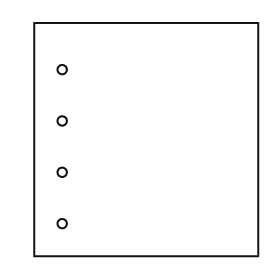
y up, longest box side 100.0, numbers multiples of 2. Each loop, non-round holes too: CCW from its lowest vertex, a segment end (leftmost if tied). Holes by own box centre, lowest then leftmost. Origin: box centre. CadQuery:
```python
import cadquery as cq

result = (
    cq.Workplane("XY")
    .moveTo(-48.0, -50.0)
    .lineTo(48.0, -50.0)
    .lineTo(48.0, 50.0)
    .lineTo(-48.0, 50.0)
    .close()
    .moveTo(-36.0, -36.0)
    .circle(2.0)
    .moveTo(-36.0, -14.0)
    .circle(2.0)
    .moveTo(-36.0, 8.0)
    .circle(2.0)
    .moveTo(-36.0, 30.0)
    .circle(2.0)
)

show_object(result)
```